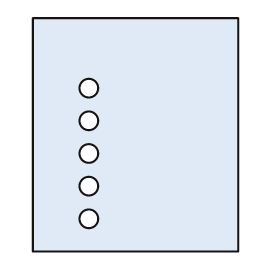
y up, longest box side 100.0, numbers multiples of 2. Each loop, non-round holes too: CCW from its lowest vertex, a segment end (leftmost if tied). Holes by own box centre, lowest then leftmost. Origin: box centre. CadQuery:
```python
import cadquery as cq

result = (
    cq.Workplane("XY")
    .moveTo(-44.0, -50.0)
    .lineTo(44.0, -50.0)
    .lineTo(44.0, 50.0)
    .lineTo(-44.0, 50.0)
    .close()
    .moveTo(-20.0, -36.0)
    .circle(4.0)
    .moveTo(-20.0, -22.0)
    .circle(4.0)
    .moveTo(-20.0, -8.0)
    .circle(4.0)
    .moveTo(-20.0, 6.0)
    .circle(4.0)
    .moveTo(-20.0, 20.0)
    .circle(4.0)
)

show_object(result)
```